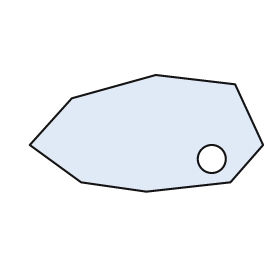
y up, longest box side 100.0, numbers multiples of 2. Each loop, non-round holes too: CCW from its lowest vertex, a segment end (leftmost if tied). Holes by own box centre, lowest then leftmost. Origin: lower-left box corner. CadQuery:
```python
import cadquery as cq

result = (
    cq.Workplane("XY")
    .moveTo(50.0, 0.0)
    .lineTo(86.0, 4.0)
    .lineTo(100.0, 20.0)
    .lineTo(88.0, 46.0)
    .lineTo(54.0, 50.0)
    .lineTo(18.0, 40.0)
    .lineTo(0.0, 20.0)
    .lineTo(22.0, 4.0)
    .close()
    .moveTo(78.0, 14.0)
    .circle(6.0)
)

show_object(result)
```